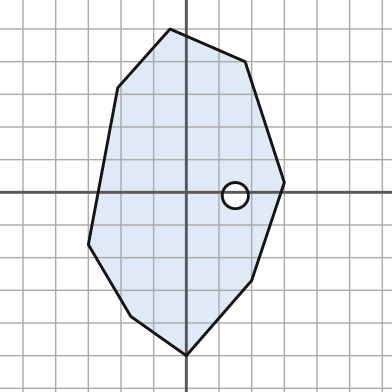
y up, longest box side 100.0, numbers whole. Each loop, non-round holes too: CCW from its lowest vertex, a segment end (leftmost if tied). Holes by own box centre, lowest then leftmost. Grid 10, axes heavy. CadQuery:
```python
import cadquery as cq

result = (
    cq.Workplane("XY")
    .moveTo(0.0, -50.0)
    .lineTo(20.0, -27.0)
    .lineTo(30.0, 3.0)
    .lineTo(18.0, 40.0)
    .lineTo(-5.0, 50.0)
    .lineTo(-21.0, 32.0)
    .lineTo(-30.0, -16.0)
    .lineTo(-17.0, -38.0)
    .close()
    .moveTo(15.0, -1.0)
    .circle(4.0)
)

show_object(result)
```